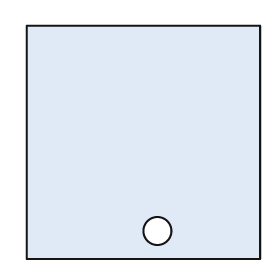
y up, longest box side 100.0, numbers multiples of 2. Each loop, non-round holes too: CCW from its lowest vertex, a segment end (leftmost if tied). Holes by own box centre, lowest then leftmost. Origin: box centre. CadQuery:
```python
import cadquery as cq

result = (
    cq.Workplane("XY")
    .moveTo(-50.0, -50.0)
    .lineTo(50.0, -50.0)
    .lineTo(50.0, 50.0)
    .lineTo(-50.0, 50.0)
    .close()
    .moveTo(6.0, -38.0)
    .circle(6.0)
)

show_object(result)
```